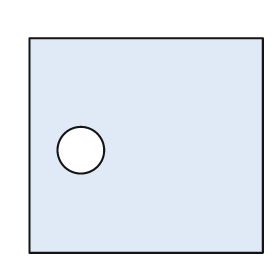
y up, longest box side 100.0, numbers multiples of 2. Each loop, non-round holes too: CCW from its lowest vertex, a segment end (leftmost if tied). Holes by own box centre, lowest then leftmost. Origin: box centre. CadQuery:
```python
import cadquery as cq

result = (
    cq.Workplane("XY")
    .moveTo(-50.0, -46.0)
    .lineTo(50.0, -46.0)
    .lineTo(50.0, 46.0)
    .lineTo(-50.0, 46.0)
    .close()
    .moveTo(-28.0, -2.0)
    .circle(10.0)
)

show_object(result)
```